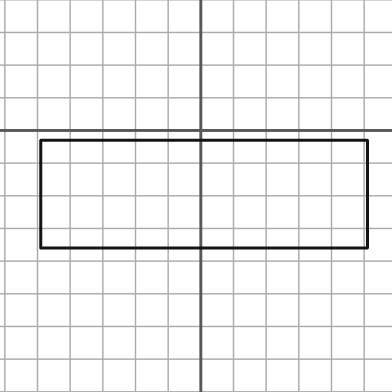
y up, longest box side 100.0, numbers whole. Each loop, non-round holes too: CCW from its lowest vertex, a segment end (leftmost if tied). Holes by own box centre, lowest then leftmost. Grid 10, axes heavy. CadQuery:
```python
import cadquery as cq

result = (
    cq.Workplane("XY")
    .moveTo(-49.0, -36.0)
    .lineTo(51.0, -36.0)
    .lineTo(51.0, -3.0)
    .lineTo(-49.0, -3.0)
    .close()
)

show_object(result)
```